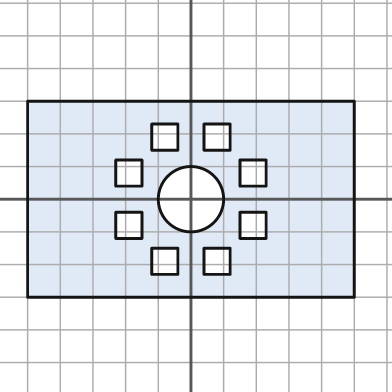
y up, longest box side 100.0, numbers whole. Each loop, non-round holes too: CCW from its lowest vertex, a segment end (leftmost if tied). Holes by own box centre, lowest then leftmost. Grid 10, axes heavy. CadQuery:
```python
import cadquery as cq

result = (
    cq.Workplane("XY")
    .moveTo(-50.0, -30.0)
    .lineTo(50.0, -30.0)
    .lineTo(50.0, 30.0)
    .lineTo(-50.0, 30.0)
    .close()
    .moveTo(-12.0, -23.0)
    .lineTo(-4.0, -23.0)
    .lineTo(-4.0, -15.0)
    .lineTo(-12.0, -15.0)
    .close()
    .moveTo(4.0, -23.0)
    .lineTo(12.0, -23.0)
    .lineTo(12.0, -15.0)
    .lineTo(4.0, -15.0)
    .close()
    .moveTo(-23.0, -12.0)
    .lineTo(-15.0, -12.0)
    .lineTo(-15.0, -4.0)
    .lineTo(-23.0, -4.0)
    .close()
    .moveTo(15.0, -12.0)
    .lineTo(23.0, -12.0)
    .lineTo(23.0, -4.0)
    .lineTo(15.0, -4.0)
    .close()
    .moveTo(0.0, 0.0)
    .circle(10.0)
    .moveTo(-23.0, 4.0)
    .lineTo(-15.0, 4.0)
    .lineTo(-15.0, 12.0)
    .lineTo(-23.0, 12.0)
    .close()
    .moveTo(15.0, 4.0)
    .lineTo(23.0, 4.0)
    .lineTo(23.0, 12.0)
    .lineTo(15.0, 12.0)
    .close()
    .moveTo(-12.0, 15.0)
    .lineTo(-4.0, 15.0)
    .lineTo(-4.0, 23.0)
    .lineTo(-12.0, 23.0)
    .close()
    .moveTo(4.0, 15.0)
    .lineTo(12.0, 15.0)
    .lineTo(12.0, 23.0)
    .lineTo(4.0, 23.0)
    .close()
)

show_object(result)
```